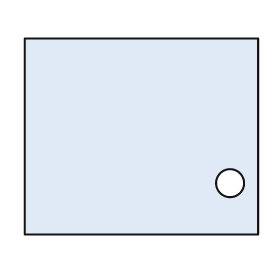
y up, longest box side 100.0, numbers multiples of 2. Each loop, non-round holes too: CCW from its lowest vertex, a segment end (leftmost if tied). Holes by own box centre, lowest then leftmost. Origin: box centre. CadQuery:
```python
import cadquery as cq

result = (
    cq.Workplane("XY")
    .moveTo(-50.0, -42.0)
    .lineTo(50.0, -42.0)
    .lineTo(50.0, 42.0)
    .lineTo(-50.0, 42.0)
    .close()
    .moveTo(38.0, -20.0)
    .circle(6.0)
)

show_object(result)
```